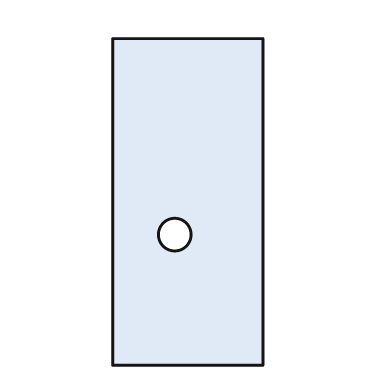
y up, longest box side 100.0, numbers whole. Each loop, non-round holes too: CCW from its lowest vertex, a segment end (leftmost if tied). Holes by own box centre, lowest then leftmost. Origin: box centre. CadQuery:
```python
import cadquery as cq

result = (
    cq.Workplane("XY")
    .moveTo(-23.0, -50.0)
    .lineTo(23.0, -50.0)
    .lineTo(23.0, 50.0)
    .lineTo(-23.0, 50.0)
    .close()
    .moveTo(-4.0, -10.0)
    .circle(5.0)
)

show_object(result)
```